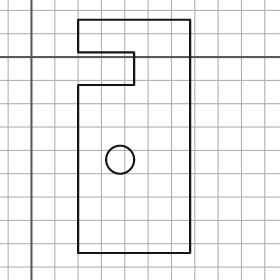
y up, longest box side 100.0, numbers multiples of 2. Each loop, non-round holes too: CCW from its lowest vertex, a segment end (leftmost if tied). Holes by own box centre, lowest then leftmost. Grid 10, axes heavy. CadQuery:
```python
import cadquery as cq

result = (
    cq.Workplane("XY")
    .moveTo(20.0, -84.0)
    .lineTo(68.0, -84.0)
    .lineTo(68.0, 16.0)
    .lineTo(20.0, 16.0)
    .lineTo(20.0, 2.0)
    .lineTo(44.0, 2.0)
    .lineTo(44.0, -12.0)
    .lineTo(20.0, -12.0)
    .close()
    .moveTo(38.0, -44.0)
    .circle(6.0)
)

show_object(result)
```